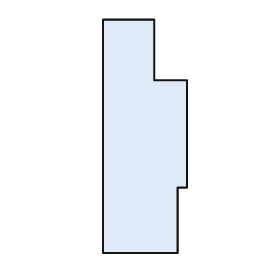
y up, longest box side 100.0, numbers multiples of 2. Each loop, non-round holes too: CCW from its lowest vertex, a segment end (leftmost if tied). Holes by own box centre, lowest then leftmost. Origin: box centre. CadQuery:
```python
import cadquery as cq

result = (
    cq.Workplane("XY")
    .moveTo(-18.0, -50.0)
    .lineTo(14.0, -50.0)
    .lineTo(14.0, -22.0)
    .lineTo(18.0, -22.0)
    .lineTo(18.0, 24.0)
    .lineTo(4.0, 24.0)
    .lineTo(4.0, 50.0)
    .lineTo(-18.0, 50.0)
    .close()
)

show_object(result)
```